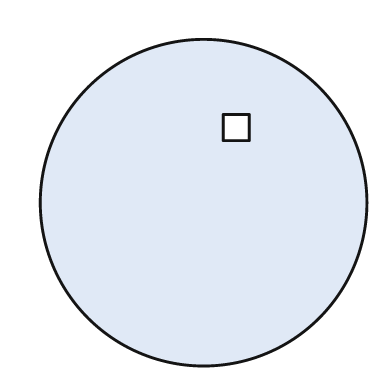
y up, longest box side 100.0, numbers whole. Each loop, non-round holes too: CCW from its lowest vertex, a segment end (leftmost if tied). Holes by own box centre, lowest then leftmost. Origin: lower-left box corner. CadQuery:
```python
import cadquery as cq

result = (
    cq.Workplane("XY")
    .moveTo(50.0, 50.0)
    .circle(50.0)
    .moveTo(56.0, 69.0)
    .lineTo(64.0, 69.0)
    .lineTo(64.0, 77.0)
    .lineTo(56.0, 77.0)
    .close()
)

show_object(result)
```